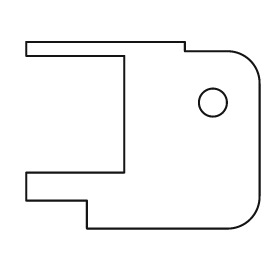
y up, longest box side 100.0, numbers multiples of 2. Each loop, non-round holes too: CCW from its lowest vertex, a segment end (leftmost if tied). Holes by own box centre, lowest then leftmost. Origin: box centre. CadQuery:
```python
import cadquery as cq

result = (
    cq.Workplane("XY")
    .moveTo(-24.0, -40.0)
    .lineTo(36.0, -40.0)
    .threePointArc((46.0, -36.0), (50.0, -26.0))
    .lineTo(50.0, 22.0)
    .threePointArc((46.0, 32.0), (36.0, 36.0))
    .lineTo(18.0, 36.0)
    .lineTo(18.0, 40.0)
    .lineTo(-50.0, 40.0)
    .lineTo(-50.0, 34.0)
    .lineTo(-8.0, 34.0)
    .lineTo(-8.0, -16.0)
    .lineTo(-50.0, -16.0)
    .lineTo(-50.0, -28.0)
    .lineTo(-24.0, -28.0)
    .close()
    .moveTo(30.0, 14.0)
    .circle(6.0)
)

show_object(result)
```